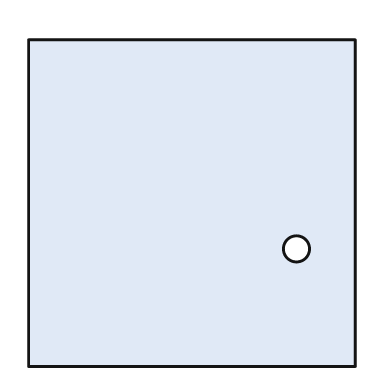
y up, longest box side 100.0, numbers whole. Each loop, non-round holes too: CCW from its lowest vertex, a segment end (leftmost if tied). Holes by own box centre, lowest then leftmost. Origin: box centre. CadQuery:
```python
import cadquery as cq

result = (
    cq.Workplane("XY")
    .moveTo(-50.0, -50.0)
    .lineTo(50.0, -50.0)
    .lineTo(50.0, 50.0)
    .lineTo(-50.0, 50.0)
    .close()
    .moveTo(32.0, -14.0)
    .circle(4.0)
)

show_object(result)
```